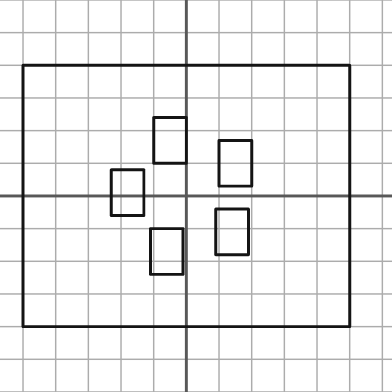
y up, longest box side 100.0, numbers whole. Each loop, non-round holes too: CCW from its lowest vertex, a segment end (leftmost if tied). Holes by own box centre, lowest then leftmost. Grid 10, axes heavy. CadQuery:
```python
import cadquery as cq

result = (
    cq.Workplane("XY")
    .moveTo(-50.0, -40.0)
    .lineTo(50.0, -40.0)
    .lineTo(50.0, 40.0)
    .lineTo(-50.0, 40.0)
    .close()
    .moveTo(-11.0, -24.0)
    .lineTo(-1.0, -24.0)
    .lineTo(-1.0, -10.0)
    .lineTo(-11.0, -10.0)
    .close()
    .moveTo(9.0, -18.0)
    .lineTo(19.0, -18.0)
    .lineTo(19.0, -4.0)
    .lineTo(9.0, -4.0)
    .close()
    .moveTo(-23.0, -6.0)
    .lineTo(-13.0, -6.0)
    .lineTo(-13.0, 8.0)
    .lineTo(-23.0, 8.0)
    .close()
    .moveTo(10.0, 3.0)
    .lineTo(20.0, 3.0)
    .lineTo(20.0, 17.0)
    .lineTo(10.0, 17.0)
    .close()
    .moveTo(-10.0, 10.0)
    .lineTo(0.0, 10.0)
    .lineTo(0.0, 24.0)
    .lineTo(-10.0, 24.0)
    .close()
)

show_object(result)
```